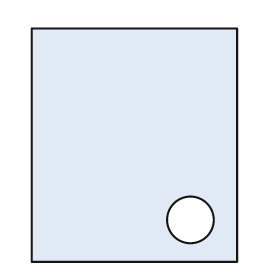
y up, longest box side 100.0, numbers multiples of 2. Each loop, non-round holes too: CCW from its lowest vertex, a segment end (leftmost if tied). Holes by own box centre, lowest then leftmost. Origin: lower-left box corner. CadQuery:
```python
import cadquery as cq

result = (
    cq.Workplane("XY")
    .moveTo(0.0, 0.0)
    .lineTo(88.0, 0.0)
    .lineTo(88.0, 100.0)
    .lineTo(0.0, 100.0)
    .close()
    .moveTo(68.0, 18.0)
    .circle(10.0)
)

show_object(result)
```